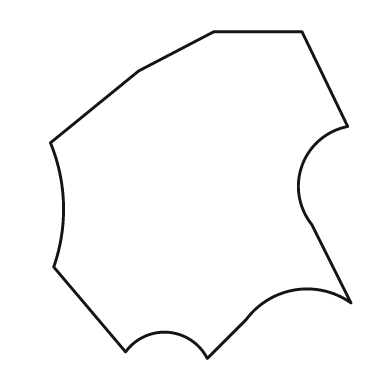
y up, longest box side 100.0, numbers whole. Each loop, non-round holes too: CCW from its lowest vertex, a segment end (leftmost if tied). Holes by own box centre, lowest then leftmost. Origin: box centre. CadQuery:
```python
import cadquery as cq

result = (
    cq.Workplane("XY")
    .moveTo(2.0, -50.0)
    .lineTo(14.0, -38.0)
    .threePointArc((29.0, -29.0), (46.0, -33.0))
    .lineTo(34.0, -9.0)
    .threePointArc((31.0, 9.0), (45.0, 21.0))
    .lineTo(31.0, 50.0)
    .lineTo(4.0, 50.0)
    .lineTo(-19.0, 38.0)
    .lineTo(-46.0, 16.0)
    .threePointArc((-42.0, -3.0), (-45.0, -22.0))
    .lineTo(-23.0, -48.0)
    .threePointArc((-10.0, -42.0), (2.0, -50.0))
    .close()
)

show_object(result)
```